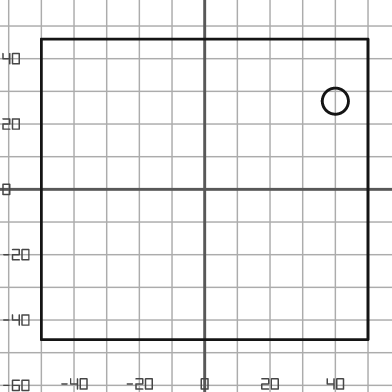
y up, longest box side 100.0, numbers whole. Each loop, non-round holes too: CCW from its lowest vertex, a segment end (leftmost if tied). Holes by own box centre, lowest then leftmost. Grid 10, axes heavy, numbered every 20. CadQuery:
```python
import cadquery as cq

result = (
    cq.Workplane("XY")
    .moveTo(-50.0, -46.0)
    .lineTo(50.0, -46.0)
    .lineTo(50.0, 46.0)
    .lineTo(-50.0, 46.0)
    .close()
    .moveTo(40.0, 27.0)
    .circle(4.0)
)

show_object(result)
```